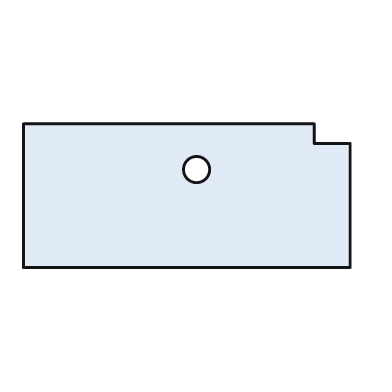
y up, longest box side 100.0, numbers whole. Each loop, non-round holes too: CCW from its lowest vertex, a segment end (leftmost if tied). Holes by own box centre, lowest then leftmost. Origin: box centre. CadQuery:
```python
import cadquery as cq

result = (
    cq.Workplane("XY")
    .moveTo(-50.0, -22.0)
    .lineTo(50.0, -22.0)
    .lineTo(50.0, 16.0)
    .lineTo(39.0, 16.0)
    .lineTo(39.0, 22.0)
    .lineTo(-50.0, 22.0)
    .close()
    .moveTo(3.0, 8.0)
    .circle(4.0)
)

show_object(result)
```